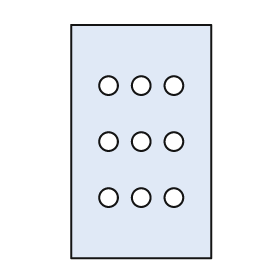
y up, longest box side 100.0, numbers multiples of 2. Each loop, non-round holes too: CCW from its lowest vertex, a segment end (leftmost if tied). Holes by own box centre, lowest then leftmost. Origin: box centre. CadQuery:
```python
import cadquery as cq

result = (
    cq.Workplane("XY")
    .moveTo(-30.0, -50.0)
    .lineTo(30.0, -50.0)
    .lineTo(30.0, 50.0)
    .lineTo(-30.0, 50.0)
    .close()
    .moveTo(-14.0, -24.0)
    .circle(4.0)
    .moveTo(0.0, -24.0)
    .circle(4.0)
    .moveTo(14.0, -24.0)
    .circle(4.0)
    .moveTo(-14.0, 0.0)
    .circle(4.0)
    .moveTo(0.0, 0.0)
    .circle(4.0)
    .moveTo(14.0, 0.0)
    .circle(4.0)
    .moveTo(-14.0, 24.0)
    .circle(4.0)
    .moveTo(0.0, 24.0)
    .circle(4.0)
    .moveTo(14.0, 24.0)
    .circle(4.0)
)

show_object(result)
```